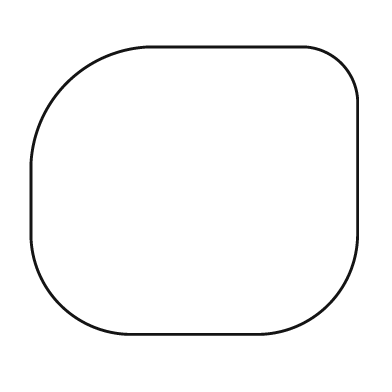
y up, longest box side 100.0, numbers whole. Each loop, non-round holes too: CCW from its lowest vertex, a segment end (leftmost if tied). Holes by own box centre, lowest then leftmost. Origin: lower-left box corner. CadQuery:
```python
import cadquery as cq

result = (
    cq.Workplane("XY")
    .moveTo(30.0, 0.0)
    .lineTo(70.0, 0.0)
    .threePointArc((91.0, 9.0), (100.0, 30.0))
    .lineTo(100.0, 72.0)
    .threePointArc((95.0, 83.0), (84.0, 88.0))
    .lineTo(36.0, 88.0)
    .threePointArc((11.0, 77.0), (0.0, 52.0))
    .lineTo(0.0, 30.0)
    .threePointArc((9.0, 9.0), (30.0, 0.0))
    .close()
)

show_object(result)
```